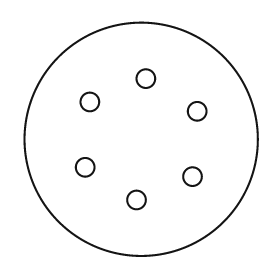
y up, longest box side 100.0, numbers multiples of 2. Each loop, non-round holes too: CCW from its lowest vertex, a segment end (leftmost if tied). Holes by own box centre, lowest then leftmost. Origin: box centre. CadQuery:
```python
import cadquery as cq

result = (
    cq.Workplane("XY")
    .moveTo(0.0, 0.0)
    .circle(50.0)
    .moveTo(-2.0, -26.0)
    .circle(4.0)
    .moveTo(22.0, -16.0)
    .circle(4.0)
    .moveTo(-24.0, -12.0)
    .circle(4.0)
    .moveTo(24.0, 12.0)
    .circle(4.0)
    .moveTo(-22.0, 16.0)
    .circle(4.0)
    .moveTo(2.0, 26.0)
    .circle(4.0)
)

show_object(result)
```